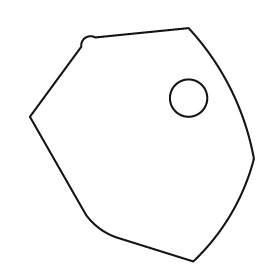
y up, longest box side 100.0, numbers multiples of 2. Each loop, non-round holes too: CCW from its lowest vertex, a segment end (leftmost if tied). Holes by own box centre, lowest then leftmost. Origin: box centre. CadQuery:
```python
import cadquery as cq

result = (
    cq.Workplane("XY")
    .moveTo(22.0, -50.0)
    .threePointArc((38.0, -30.0), (48.0, -6.0))
    .threePointArc((38.0, 24.0), (20.0, 50.0))
    .lineTo(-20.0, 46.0)
    .threePointArc((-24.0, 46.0), (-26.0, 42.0))
    .lineTo(-48.0, 12.0)
    .lineTo(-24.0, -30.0)
    .threePointArc((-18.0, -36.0), (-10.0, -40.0))
    .close()
    .moveTo(20.0, 20.0)
    .circle(8.0)
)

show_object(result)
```